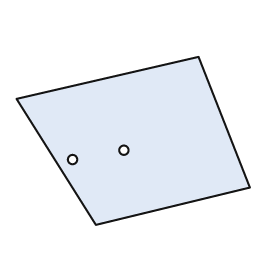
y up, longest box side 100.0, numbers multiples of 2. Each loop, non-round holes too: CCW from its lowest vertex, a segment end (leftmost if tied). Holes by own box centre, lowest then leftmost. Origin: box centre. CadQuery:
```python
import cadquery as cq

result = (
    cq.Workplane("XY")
    .moveTo(-16.0, -36.0)
    .lineTo(50.0, -20.0)
    .lineTo(28.0, 36.0)
    .lineTo(-50.0, 18.0)
    .close()
    .moveTo(-26.0, -8.0)
    .circle(2.0)
    .moveTo(-4.0, -4.0)
    .circle(2.0)
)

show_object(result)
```